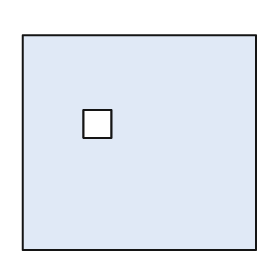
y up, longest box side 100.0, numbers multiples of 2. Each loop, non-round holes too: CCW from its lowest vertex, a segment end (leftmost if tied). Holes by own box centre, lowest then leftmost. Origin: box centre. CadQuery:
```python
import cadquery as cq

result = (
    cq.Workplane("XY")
    .moveTo(-50.0, -46.0)
    .lineTo(50.0, -46.0)
    .lineTo(50.0, 46.0)
    .lineTo(-50.0, 46.0)
    .close()
    .moveTo(-24.0, 2.0)
    .lineTo(-12.0, 2.0)
    .lineTo(-12.0, 14.0)
    .lineTo(-24.0, 14.0)
    .close()
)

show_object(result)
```